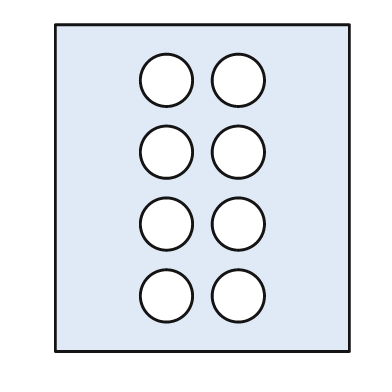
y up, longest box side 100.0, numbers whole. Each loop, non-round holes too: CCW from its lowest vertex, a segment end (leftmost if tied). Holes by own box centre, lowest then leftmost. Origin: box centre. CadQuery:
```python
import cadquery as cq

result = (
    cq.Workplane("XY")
    .moveTo(-45.0, -50.0)
    .lineTo(45.0, -50.0)
    .lineTo(45.0, 50.0)
    .lineTo(-45.0, 50.0)
    .close()
    .moveTo(-11.0, -33.0)
    .circle(8.0)
    .moveTo(11.0, -33.0)
    .circle(8.0)
    .moveTo(-11.0, -11.0)
    .circle(8.0)
    .moveTo(11.0, -11.0)
    .circle(8.0)
    .moveTo(-11.0, 11.0)
    .circle(8.0)
    .moveTo(11.0, 11.0)
    .circle(8.0)
    .moveTo(-11.0, 33.0)
    .circle(8.0)
    .moveTo(11.0, 33.0)
    .circle(8.0)
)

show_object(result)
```